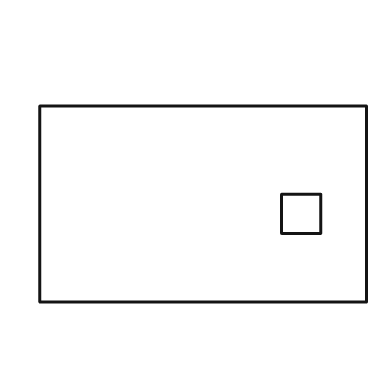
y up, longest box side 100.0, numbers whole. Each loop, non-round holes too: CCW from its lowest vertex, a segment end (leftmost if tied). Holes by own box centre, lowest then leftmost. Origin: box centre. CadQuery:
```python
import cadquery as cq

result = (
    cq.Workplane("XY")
    .moveTo(-50.0, -30.0)
    .lineTo(50.0, -30.0)
    .lineTo(50.0, 30.0)
    .lineTo(-50.0, 30.0)
    .close()
    .moveTo(24.0, -9.0)
    .lineTo(36.0, -9.0)
    .lineTo(36.0, 3.0)
    .lineTo(24.0, 3.0)
    .close()
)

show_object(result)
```